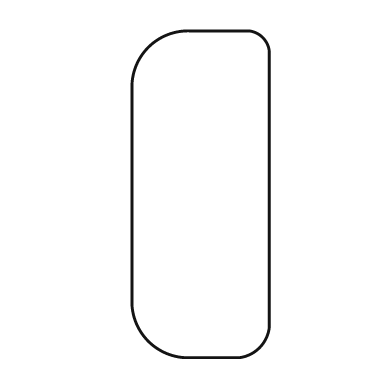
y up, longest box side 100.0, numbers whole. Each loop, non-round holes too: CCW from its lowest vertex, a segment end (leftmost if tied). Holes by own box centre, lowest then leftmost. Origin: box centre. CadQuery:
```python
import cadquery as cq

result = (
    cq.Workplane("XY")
    .moveTo(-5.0, -50.0)
    .lineTo(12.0, -50.0)
    .threePointArc((18.0, -47.0), (21.0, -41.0))
    .lineTo(21.0, 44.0)
    .threePointArc((19.0, 48.0), (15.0, 50.0))
    .lineTo(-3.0, 50.0)
    .threePointArc((-16.0, 45.0), (-21.0, 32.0))
    .lineTo(-21.0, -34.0)
    .threePointArc((-16.0, -45.0), (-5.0, -50.0))
    .close()
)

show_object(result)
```